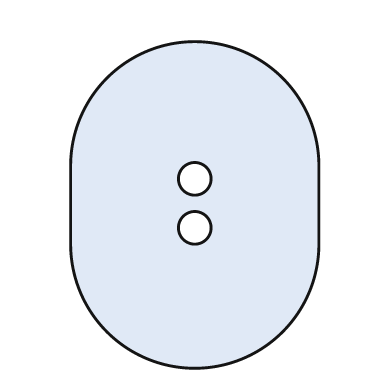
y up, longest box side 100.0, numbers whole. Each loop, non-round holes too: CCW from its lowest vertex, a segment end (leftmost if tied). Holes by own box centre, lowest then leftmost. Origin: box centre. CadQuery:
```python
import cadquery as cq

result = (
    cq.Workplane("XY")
    .moveTo(-38.0, -12.0)
    .threePointArc((0.0, -50.0), (38.0, -12.0))
    .lineTo(38.0, 12.0)
    .threePointArc((0.0, 50.0), (-38.0, 12.0))
    .close()
    .moveTo(0.0, -7.0)
    .circle(5.0)
    .moveTo(0.0, 8.0)
    .circle(5.0)
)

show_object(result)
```